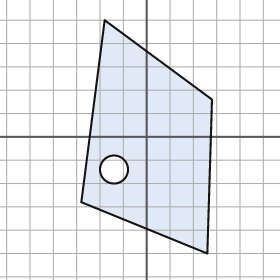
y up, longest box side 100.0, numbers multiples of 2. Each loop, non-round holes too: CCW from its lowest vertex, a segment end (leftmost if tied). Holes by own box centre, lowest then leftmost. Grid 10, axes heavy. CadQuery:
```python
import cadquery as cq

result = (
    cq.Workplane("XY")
    .moveTo(26.0, -50.0)
    .lineTo(28.0, 16.0)
    .lineTo(-18.0, 50.0)
    .lineTo(-28.0, -28.0)
    .close()
    .moveTo(-14.0, -14.0)
    .circle(6.0)
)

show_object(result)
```